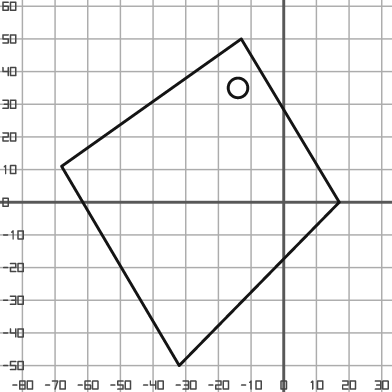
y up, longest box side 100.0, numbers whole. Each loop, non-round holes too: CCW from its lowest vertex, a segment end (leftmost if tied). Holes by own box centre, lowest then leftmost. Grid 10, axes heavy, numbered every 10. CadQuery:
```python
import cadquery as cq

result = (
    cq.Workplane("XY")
    .moveTo(-32.0, -50.0)
    .lineTo(17.0, 0.0)
    .lineTo(-13.0, 50.0)
    .lineTo(-68.0, 11.0)
    .close()
    .moveTo(-14.0, 35.0)
    .circle(3.0)
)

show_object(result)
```